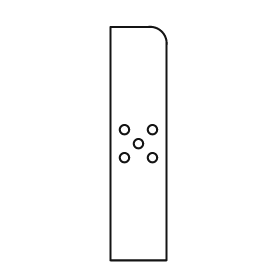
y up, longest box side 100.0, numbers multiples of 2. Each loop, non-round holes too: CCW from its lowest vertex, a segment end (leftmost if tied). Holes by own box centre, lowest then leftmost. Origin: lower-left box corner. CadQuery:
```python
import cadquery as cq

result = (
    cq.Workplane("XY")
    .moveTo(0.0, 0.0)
    .lineTo(24.0, 0.0)
    .lineTo(24.0, 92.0)
    .threePointArc((22.0, 98.0), (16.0, 100.0))
    .lineTo(0.0, 100.0)
    .close()
    .moveTo(6.0, 44.0)
    .circle(2.0)
    .moveTo(18.0, 44.0)
    .circle(2.0)
    .moveTo(12.0, 50.0)
    .circle(2.0)
    .moveTo(6.0, 56.0)
    .circle(2.0)
    .moveTo(18.0, 56.0)
    .circle(2.0)
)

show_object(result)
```